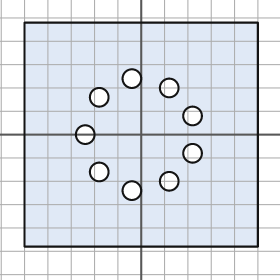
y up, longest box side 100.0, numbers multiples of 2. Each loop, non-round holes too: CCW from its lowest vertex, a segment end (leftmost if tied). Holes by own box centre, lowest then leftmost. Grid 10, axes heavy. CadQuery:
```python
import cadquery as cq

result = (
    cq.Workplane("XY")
    .moveTo(-50.0, -48.0)
    .lineTo(50.0, -48.0)
    .lineTo(50.0, 48.0)
    .lineTo(-50.0, 48.0)
    .close()
    .moveTo(-4.0, -24.0)
    .circle(4.0)
    .moveTo(12.0, -20.0)
    .circle(4.0)
    .moveTo(-18.0, -16.0)
    .circle(4.0)
    .moveTo(22.0, -8.0)
    .circle(4.0)
    .moveTo(-24.0, 0.0)
    .circle(4.0)
    .moveTo(22.0, 8.0)
    .circle(4.0)
    .moveTo(-18.0, 16.0)
    .circle(4.0)
    .moveTo(12.0, 20.0)
    .circle(4.0)
    .moveTo(-4.0, 24.0)
    .circle(4.0)
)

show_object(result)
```